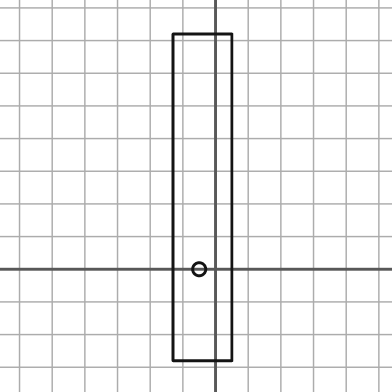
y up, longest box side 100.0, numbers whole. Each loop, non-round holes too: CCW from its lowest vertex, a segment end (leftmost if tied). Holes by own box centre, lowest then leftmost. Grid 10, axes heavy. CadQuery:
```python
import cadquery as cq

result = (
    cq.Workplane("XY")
    .moveTo(-13.0, -28.0)
    .lineTo(5.0, -28.0)
    .lineTo(5.0, 72.0)
    .lineTo(-13.0, 72.0)
    .close()
    .moveTo(-5.0, 0.0)
    .circle(2.0)
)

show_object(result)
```